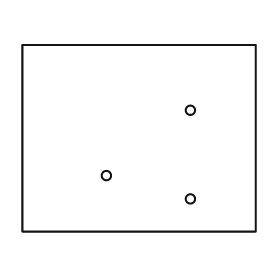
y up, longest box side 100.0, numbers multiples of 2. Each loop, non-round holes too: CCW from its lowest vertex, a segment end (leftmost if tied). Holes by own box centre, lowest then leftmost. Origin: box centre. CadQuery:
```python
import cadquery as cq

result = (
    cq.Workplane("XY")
    .moveTo(-50.0, -40.0)
    .lineTo(50.0, -40.0)
    .lineTo(50.0, 40.0)
    .lineTo(-50.0, 40.0)
    .close()
    .moveTo(22.0, -26.0)
    .circle(2.0)
    .moveTo(-14.0, -16.0)
    .circle(2.0)
    .moveTo(22.0, 12.0)
    .circle(2.0)
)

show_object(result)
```